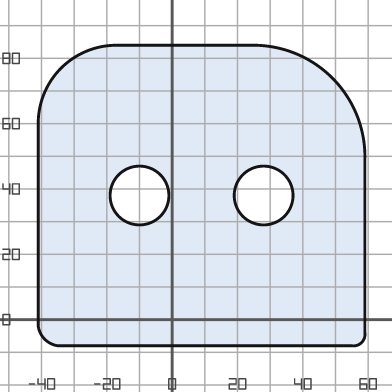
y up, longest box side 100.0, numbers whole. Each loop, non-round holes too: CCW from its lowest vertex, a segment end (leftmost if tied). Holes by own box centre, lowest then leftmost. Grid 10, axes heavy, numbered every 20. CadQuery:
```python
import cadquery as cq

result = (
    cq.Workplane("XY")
    .moveTo(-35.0, -8.0)
    .lineTo(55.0, -8.0)
    .threePointArc((58.0, -7.0), (59.0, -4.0))
    .lineTo(59.0, 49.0)
    .threePointArc((49.0, 74.0), (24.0, 84.0))
    .lineTo(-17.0, 84.0)
    .threePointArc((-34.0, 77.0), (-41.0, 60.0))
    .lineTo(-41.0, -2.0)
    .threePointArc((-39.0, -6.0), (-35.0, -8.0))
    .close()
    .moveTo(-10.0, 38.0)
    .circle(9.0)
    .moveTo(28.0, 38.0)
    .circle(9.0)
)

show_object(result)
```